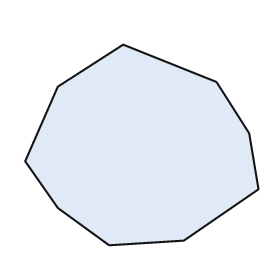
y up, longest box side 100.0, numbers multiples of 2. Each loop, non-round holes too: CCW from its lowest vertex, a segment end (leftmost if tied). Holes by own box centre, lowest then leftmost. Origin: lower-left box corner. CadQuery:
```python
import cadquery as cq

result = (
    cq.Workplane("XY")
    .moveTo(36.0, 0.0)
    .lineTo(68.0, 2.0)
    .lineTo(100.0, 24.0)
    .lineTo(96.0, 48.0)
    .lineTo(82.0, 70.0)
    .lineTo(42.0, 86.0)
    .lineTo(14.0, 68.0)
    .lineTo(0.0, 36.0)
    .lineTo(14.0, 16.0)
    .close()
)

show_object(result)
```